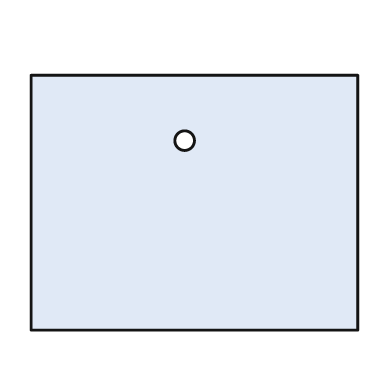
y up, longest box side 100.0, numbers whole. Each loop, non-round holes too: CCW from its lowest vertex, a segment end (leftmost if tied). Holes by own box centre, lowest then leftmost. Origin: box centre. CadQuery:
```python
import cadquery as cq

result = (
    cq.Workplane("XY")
    .moveTo(-50.0, -39.0)
    .lineTo(50.0, -39.0)
    .lineTo(50.0, 39.0)
    .lineTo(-50.0, 39.0)
    .close()
    .moveTo(-3.0, 19.0)
    .circle(3.0)
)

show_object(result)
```